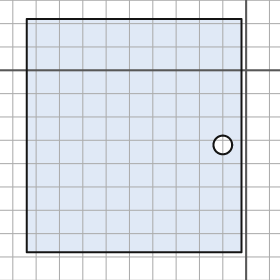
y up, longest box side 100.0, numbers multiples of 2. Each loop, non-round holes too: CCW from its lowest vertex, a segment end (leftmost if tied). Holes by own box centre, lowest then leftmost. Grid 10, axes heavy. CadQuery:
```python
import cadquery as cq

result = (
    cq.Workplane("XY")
    .moveTo(-94.0, -78.0)
    .lineTo(-2.0, -78.0)
    .lineTo(-2.0, 22.0)
    .lineTo(-94.0, 22.0)
    .close()
    .moveTo(-10.0, -32.0)
    .circle(4.0)
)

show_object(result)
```